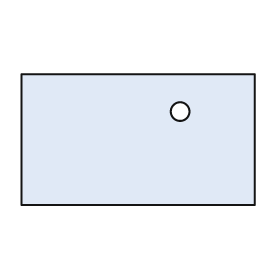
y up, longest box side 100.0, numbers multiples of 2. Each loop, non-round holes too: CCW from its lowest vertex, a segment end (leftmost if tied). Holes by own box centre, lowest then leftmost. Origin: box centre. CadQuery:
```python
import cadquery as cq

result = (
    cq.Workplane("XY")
    .moveTo(-50.0, -28.0)
    .lineTo(50.0, -28.0)
    .lineTo(50.0, 28.0)
    .lineTo(-50.0, 28.0)
    .close()
    .moveTo(18.0, 12.0)
    .circle(4.0)
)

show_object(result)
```